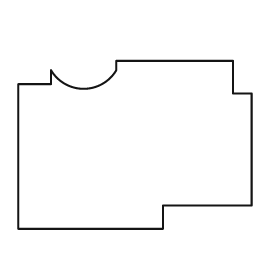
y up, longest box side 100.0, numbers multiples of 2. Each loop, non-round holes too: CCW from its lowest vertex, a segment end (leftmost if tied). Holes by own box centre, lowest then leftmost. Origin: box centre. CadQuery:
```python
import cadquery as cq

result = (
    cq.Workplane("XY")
    .moveTo(-50.0, -36.0)
    .lineTo(12.0, -36.0)
    .lineTo(12.0, -26.0)
    .lineTo(50.0, -26.0)
    .lineTo(50.0, 22.0)
    .lineTo(42.0, 22.0)
    .lineTo(42.0, 36.0)
    .lineTo(-8.0, 36.0)
    .lineTo(-8.0, 32.0)
    .threePointArc((-22.0, 24.0), (-36.0, 32.0))
    .lineTo(-36.0, 26.0)
    .lineTo(-50.0, 26.0)
    .close()
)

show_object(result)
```